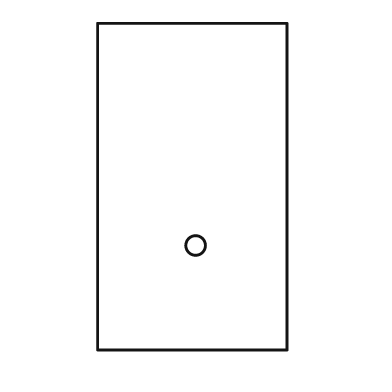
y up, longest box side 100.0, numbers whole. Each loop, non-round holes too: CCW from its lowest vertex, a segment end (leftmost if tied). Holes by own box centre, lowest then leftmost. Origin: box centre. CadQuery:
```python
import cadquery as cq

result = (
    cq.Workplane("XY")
    .moveTo(-29.0, -50.0)
    .lineTo(29.0, -50.0)
    .lineTo(29.0, 50.0)
    .lineTo(-29.0, 50.0)
    .close()
    .moveTo(1.0, -18.0)
    .circle(3.0)
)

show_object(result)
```